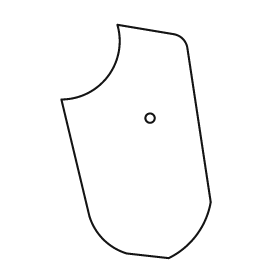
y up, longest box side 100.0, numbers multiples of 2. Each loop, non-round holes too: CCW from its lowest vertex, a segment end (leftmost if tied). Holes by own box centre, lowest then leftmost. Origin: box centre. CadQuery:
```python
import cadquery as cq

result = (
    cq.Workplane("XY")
    .moveTo(14.0, -50.0)
    .threePointArc((26.0, -40.0), (32.0, -26.0))
    .lineTo(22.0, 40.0)
    .threePointArc((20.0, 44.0), (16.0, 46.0))
    .lineTo(-8.0, 50.0)
    .threePointArc((-12.0, 28.0), (-32.0, 18.0))
    .lineTo(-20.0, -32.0)
    .threePointArc((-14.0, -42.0), (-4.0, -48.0))
    .close()
    .moveTo(6.0, 10.0)
    .circle(2.0)
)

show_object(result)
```